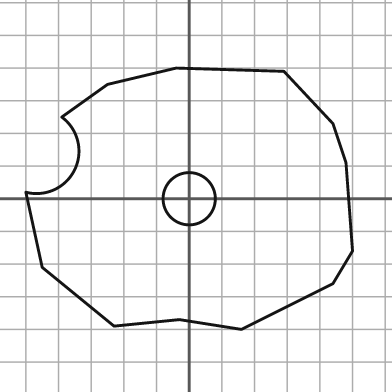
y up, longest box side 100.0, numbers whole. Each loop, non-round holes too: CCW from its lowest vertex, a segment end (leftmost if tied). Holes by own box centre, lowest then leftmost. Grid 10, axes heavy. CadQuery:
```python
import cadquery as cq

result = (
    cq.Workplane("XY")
    .moveTo(16.0, -40.0)
    .lineTo(44.0, -26.0)
    .lineTo(50.0, -16.0)
    .lineTo(48.0, 11.0)
    .lineTo(44.0, 23.0)
    .lineTo(29.0, 39.0)
    .lineTo(-4.0, 40.0)
    .lineTo(-25.0, 35.0)
    .lineTo(-39.0, 25.0)
    .threePointArc((-35.0, 9.0), (-50.0, 2.0))
    .lineTo(-45.0, -21.0)
    .lineTo(-23.0, -39.0)
    .lineTo(-3.0, -37.0)
    .close()
    .moveTo(0.0, 0.0)
    .circle(8.0)
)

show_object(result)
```